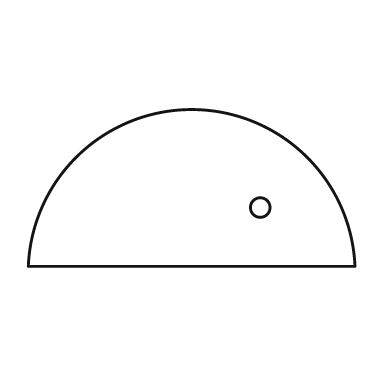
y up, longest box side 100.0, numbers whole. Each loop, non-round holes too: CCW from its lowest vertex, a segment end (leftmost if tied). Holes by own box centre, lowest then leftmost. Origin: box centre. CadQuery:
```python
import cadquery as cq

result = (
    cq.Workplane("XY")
    .moveTo(-50.0, -24.0)
    .lineTo(50.0, -24.0)
    .threePointArc((0.0, 24.0), (-50.0, -24.0))
    .close()
    .moveTo(21.0, -6.0)
    .circle(3.0)
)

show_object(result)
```